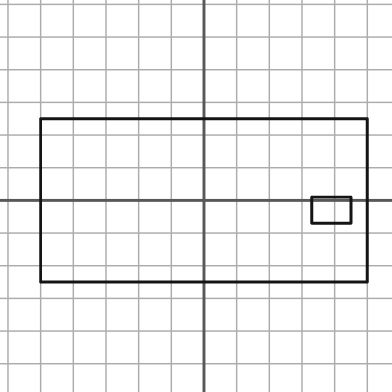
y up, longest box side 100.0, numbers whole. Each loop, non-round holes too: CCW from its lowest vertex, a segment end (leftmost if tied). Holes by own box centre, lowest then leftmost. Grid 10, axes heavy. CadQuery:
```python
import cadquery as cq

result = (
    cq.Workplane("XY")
    .moveTo(-50.0, -25.0)
    .lineTo(50.0, -25.0)
    .lineTo(50.0, 25.0)
    .lineTo(-50.0, 25.0)
    .close()
    .moveTo(33.0, -7.0)
    .lineTo(45.0, -7.0)
    .lineTo(45.0, 1.0)
    .lineTo(33.0, 1.0)
    .close()
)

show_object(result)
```